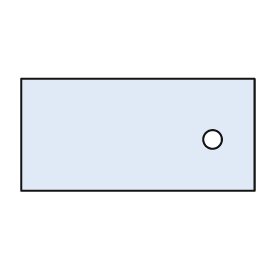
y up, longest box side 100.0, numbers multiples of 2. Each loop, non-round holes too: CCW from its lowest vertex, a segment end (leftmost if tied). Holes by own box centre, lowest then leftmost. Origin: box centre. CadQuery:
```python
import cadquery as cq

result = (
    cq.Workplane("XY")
    .moveTo(-50.0, -24.0)
    .lineTo(50.0, -24.0)
    .lineTo(50.0, 24.0)
    .lineTo(-50.0, 24.0)
    .close()
    .moveTo(32.0, -2.0)
    .circle(4.0)
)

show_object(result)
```